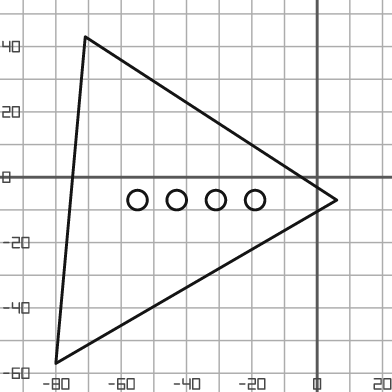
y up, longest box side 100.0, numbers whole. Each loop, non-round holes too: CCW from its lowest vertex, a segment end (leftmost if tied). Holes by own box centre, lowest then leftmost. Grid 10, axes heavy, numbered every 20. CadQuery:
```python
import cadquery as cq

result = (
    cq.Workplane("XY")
    .moveTo(-80.0, -57.0)
    .lineTo(6.0, -7.0)
    .lineTo(-71.0, 43.0)
    .close()
    .moveTo(-55.0, -7.0)
    .circle(3.0)
    .moveTo(-43.0, -7.0)
    .circle(3.0)
    .moveTo(-31.0, -7.0)
    .circle(3.0)
    .moveTo(-19.0, -7.0)
    .circle(3.0)
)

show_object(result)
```